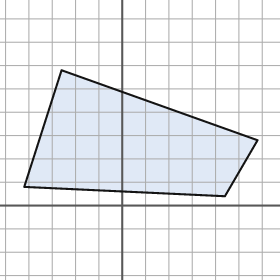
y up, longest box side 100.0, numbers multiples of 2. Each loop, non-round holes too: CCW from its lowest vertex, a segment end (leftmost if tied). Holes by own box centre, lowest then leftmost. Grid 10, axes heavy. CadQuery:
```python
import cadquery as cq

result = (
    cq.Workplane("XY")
    .moveTo(44.0, 4.0)
    .lineTo(58.0, 28.0)
    .lineTo(-26.0, 58.0)
    .lineTo(-42.0, 8.0)
    .close()
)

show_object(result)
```